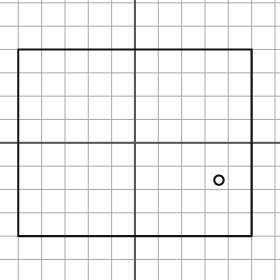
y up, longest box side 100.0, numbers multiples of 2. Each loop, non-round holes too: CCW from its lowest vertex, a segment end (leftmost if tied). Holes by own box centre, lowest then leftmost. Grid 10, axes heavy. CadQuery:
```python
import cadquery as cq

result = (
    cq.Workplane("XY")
    .moveTo(-50.0, -40.0)
    .lineTo(50.0, -40.0)
    .lineTo(50.0, 40.0)
    .lineTo(-50.0, 40.0)
    .close()
    .moveTo(36.0, -16.0)
    .circle(2.0)
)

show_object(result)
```